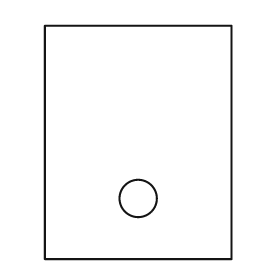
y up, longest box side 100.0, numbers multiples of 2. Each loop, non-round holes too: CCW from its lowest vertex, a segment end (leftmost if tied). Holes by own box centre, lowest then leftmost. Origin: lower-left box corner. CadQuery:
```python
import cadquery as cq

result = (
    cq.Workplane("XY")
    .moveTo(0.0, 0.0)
    .lineTo(80.0, 0.0)
    .lineTo(80.0, 100.0)
    .lineTo(0.0, 100.0)
    .close()
    .moveTo(40.0, 26.0)
    .circle(8.0)
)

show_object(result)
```